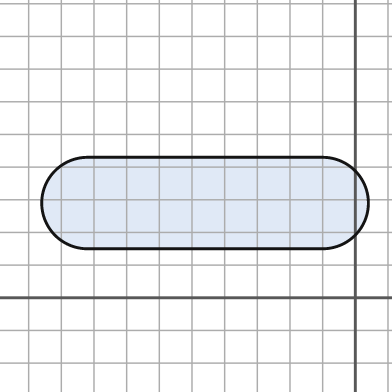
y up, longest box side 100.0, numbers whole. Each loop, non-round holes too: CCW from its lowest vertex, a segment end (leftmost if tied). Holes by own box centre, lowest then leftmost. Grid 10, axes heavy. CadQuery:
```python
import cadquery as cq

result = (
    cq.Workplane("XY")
    .moveTo(-82.0, 15.0)
    .lineTo(-10.0, 15.0)
    .threePointArc((4.0, 29.0), (-10.0, 43.0))
    .lineTo(-82.0, 43.0)
    .threePointArc((-96.0, 29.0), (-82.0, 15.0))
    .close()
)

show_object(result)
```